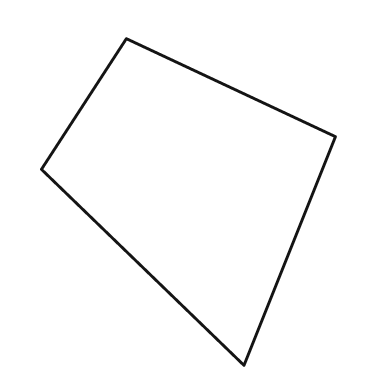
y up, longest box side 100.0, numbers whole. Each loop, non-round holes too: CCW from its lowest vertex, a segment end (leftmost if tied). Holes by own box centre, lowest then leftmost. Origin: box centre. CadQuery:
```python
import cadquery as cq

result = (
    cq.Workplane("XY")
    .moveTo(17.0, -50.0)
    .lineTo(45.0, 20.0)
    .lineTo(-19.0, 50.0)
    .lineTo(-45.0, 10.0)
    .close()
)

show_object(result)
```